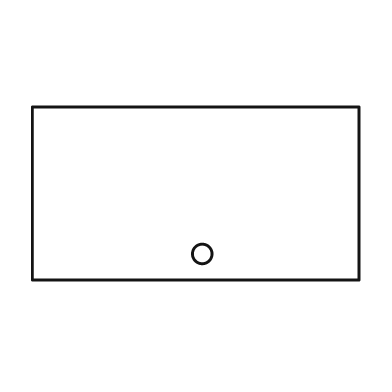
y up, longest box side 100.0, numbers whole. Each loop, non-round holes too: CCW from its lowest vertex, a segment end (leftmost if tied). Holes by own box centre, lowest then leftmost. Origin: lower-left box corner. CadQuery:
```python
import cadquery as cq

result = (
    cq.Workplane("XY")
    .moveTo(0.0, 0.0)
    .lineTo(100.0, 0.0)
    .lineTo(100.0, 53.0)
    .lineTo(0.0, 53.0)
    .close()
    .moveTo(52.0, 8.0)
    .circle(3.0)
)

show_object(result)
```